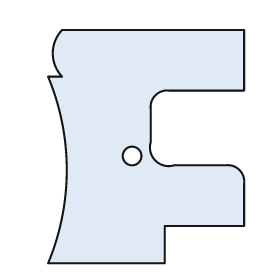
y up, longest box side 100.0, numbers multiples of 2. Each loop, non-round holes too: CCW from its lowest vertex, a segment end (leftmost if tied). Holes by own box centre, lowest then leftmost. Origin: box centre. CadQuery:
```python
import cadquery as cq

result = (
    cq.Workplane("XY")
    .moveTo(-42.0, -50.0)
    .lineTo(8.0, -50.0)
    .lineTo(8.0, -34.0)
    .lineTo(42.0, -34.0)
    .lineTo(42.0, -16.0)
    .threePointArc((40.0, -10.0), (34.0, -8.0))
    .lineTo(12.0, -8.0)
    .threePointArc((4.0, -6.0), (2.0, 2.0))
    .lineTo(2.0, 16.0)
    .threePointArc((4.0, 22.0), (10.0, 24.0))
    .lineTo(42.0, 24.0)
    .lineTo(42.0, 50.0)
    .lineTo(-36.0, 50.0)
    .threePointArc((-40.0, 40.0), (-36.0, 30.0))
    .lineTo(-42.0, 30.0)
    .threePointArc((-34.0, -10.0), (-42.0, -50.0))
    .close()
    .moveTo(-6.0, -4.0)
    .circle(4.0)
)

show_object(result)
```